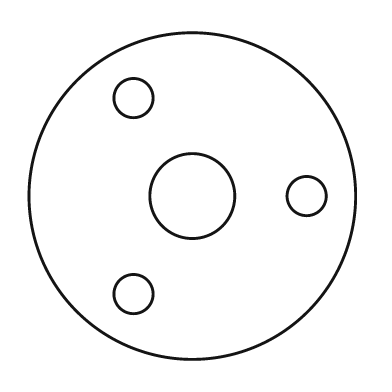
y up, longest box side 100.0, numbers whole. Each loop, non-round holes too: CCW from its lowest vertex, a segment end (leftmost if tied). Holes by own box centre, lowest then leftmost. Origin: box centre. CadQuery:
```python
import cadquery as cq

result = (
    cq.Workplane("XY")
    .moveTo(0.0, 0.0)
    .circle(50.0)
    .moveTo(-18.0, -30.0)
    .circle(6.0)
    .moveTo(0.0, 0.0)
    .circle(13.0)
    .moveTo(35.0, 0.0)
    .circle(6.0)
    .moveTo(-18.0, 30.0)
    .circle(6.0)
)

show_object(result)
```